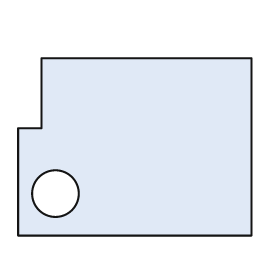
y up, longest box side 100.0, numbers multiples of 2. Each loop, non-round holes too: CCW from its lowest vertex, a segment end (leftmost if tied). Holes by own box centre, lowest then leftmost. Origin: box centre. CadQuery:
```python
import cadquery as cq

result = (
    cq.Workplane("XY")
    .moveTo(-50.0, -38.0)
    .lineTo(50.0, -38.0)
    .lineTo(50.0, 38.0)
    .lineTo(-40.0, 38.0)
    .lineTo(-40.0, 8.0)
    .lineTo(-50.0, 8.0)
    .close()
    .moveTo(-34.0, -20.0)
    .circle(10.0)
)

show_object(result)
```